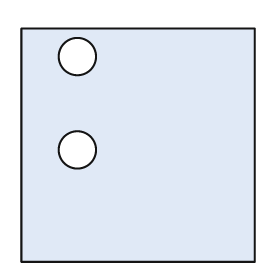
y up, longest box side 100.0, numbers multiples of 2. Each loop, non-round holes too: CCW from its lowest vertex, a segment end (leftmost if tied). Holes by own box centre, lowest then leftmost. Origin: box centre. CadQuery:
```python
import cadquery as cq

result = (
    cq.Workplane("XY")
    .moveTo(-50.0, -50.0)
    .lineTo(50.0, -50.0)
    .lineTo(50.0, 50.0)
    .lineTo(-50.0, 50.0)
    .close()
    .moveTo(-26.0, -2.0)
    .circle(8.0)
    .moveTo(-26.0, 38.0)
    .circle(8.0)
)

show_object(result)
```